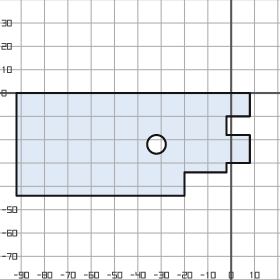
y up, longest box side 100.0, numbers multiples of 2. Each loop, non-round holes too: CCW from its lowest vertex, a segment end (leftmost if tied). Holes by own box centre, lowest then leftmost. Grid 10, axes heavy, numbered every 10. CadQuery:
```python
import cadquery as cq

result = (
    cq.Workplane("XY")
    .moveTo(-92.0, -44.0)
    .lineTo(-20.0, -44.0)
    .lineTo(-20.0, -34.0)
    .lineTo(-2.0, -34.0)
    .lineTo(-2.0, -30.0)
    .lineTo(8.0, -30.0)
    .lineTo(8.0, -18.0)
    .lineTo(-2.0, -18.0)
    .lineTo(-2.0, -10.0)
    .lineTo(8.0, -10.0)
    .lineTo(8.0, 0.0)
    .lineTo(-92.0, 0.0)
    .close()
    .moveTo(-32.0, -22.0)
    .circle(4.0)
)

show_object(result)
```